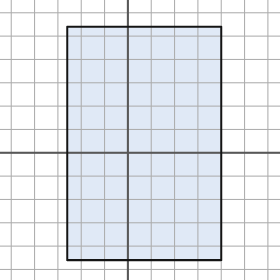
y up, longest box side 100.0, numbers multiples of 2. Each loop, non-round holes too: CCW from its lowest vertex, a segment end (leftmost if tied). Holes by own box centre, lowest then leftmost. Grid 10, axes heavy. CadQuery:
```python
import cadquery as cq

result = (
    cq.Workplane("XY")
    .moveTo(-26.0, -46.0)
    .lineTo(40.0, -46.0)
    .lineTo(40.0, 54.0)
    .lineTo(-26.0, 54.0)
    .close()
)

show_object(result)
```